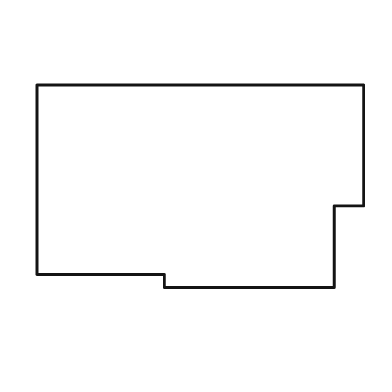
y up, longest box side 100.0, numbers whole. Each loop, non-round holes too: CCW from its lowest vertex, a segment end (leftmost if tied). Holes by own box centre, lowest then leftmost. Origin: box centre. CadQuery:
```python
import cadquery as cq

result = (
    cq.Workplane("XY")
    .moveTo(-11.0, -31.0)
    .lineTo(41.0, -31.0)
    .lineTo(41.0, -6.0)
    .lineTo(50.0, -6.0)
    .lineTo(50.0, 31.0)
    .lineTo(-50.0, 31.0)
    .lineTo(-50.0, -27.0)
    .lineTo(-11.0, -27.0)
    .close()
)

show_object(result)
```